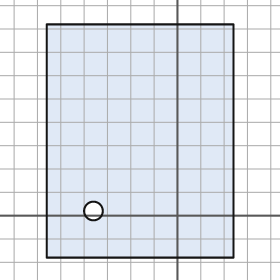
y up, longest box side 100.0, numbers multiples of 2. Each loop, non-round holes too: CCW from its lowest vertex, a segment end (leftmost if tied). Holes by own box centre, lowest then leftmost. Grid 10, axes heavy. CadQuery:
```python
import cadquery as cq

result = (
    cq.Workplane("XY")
    .moveTo(-56.0, -18.0)
    .lineTo(24.0, -18.0)
    .lineTo(24.0, 82.0)
    .lineTo(-56.0, 82.0)
    .close()
    .moveTo(-36.0, 2.0)
    .circle(4.0)
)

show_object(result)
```